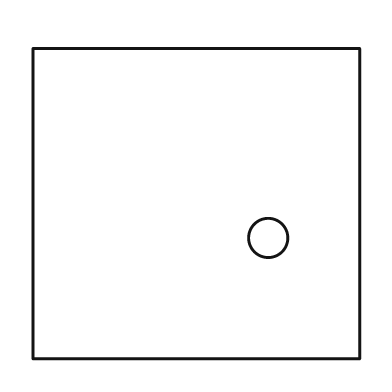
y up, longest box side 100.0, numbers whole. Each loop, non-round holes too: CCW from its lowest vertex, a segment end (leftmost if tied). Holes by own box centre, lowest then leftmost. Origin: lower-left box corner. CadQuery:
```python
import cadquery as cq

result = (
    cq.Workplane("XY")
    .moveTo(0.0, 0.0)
    .lineTo(100.0, 0.0)
    .lineTo(100.0, 95.0)
    .lineTo(0.0, 95.0)
    .close()
    .moveTo(72.0, 37.0)
    .circle(6.0)
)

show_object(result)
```